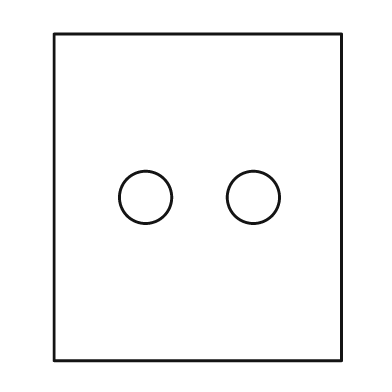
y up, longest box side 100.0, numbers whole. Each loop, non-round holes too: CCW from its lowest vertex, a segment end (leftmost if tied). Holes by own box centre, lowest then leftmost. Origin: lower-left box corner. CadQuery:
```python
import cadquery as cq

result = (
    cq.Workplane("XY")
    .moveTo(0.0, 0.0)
    .lineTo(88.0, 0.0)
    .lineTo(88.0, 100.0)
    .lineTo(0.0, 100.0)
    .close()
    .moveTo(28.0, 50.0)
    .circle(8.0)
    .moveTo(61.0, 50.0)
    .circle(8.0)
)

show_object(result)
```